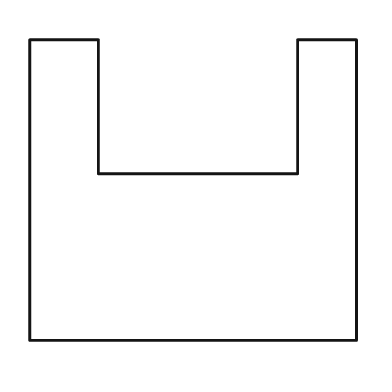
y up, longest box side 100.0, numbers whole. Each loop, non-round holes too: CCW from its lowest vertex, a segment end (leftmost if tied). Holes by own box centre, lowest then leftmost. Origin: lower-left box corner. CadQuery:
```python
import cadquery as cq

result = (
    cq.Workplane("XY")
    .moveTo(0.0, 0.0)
    .lineTo(100.0, 0.0)
    .lineTo(100.0, 92.0)
    .lineTo(82.0, 92.0)
    .lineTo(82.0, 51.0)
    .lineTo(21.0, 51.0)
    .lineTo(21.0, 92.0)
    .lineTo(0.0, 92.0)
    .close()
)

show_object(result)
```